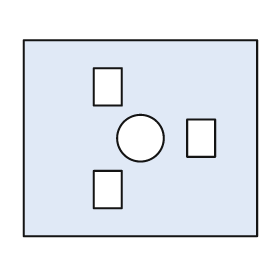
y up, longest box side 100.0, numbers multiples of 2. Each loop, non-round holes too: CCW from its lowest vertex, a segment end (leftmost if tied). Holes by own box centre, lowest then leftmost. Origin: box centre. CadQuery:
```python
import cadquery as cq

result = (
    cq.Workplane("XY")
    .moveTo(-50.0, -42.0)
    .lineTo(50.0, -42.0)
    .lineTo(50.0, 42.0)
    .lineTo(-50.0, 42.0)
    .close()
    .moveTo(-20.0, -30.0)
    .lineTo(-8.0, -30.0)
    .lineTo(-8.0, -14.0)
    .lineTo(-20.0, -14.0)
    .close()
    .moveTo(0.0, 0.0)
    .circle(10.0)
    .moveTo(20.0, -8.0)
    .lineTo(32.0, -8.0)
    .lineTo(32.0, 8.0)
    .lineTo(20.0, 8.0)
    .close()
    .moveTo(-20.0, 14.0)
    .lineTo(-8.0, 14.0)
    .lineTo(-8.0, 30.0)
    .lineTo(-20.0, 30.0)
    .close()
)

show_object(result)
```